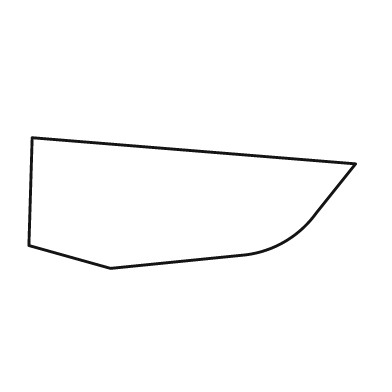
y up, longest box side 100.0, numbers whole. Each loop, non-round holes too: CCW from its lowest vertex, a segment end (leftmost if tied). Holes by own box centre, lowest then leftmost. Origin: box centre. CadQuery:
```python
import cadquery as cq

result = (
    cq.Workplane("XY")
    .moveTo(-25.0, -20.0)
    .lineTo(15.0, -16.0)
    .threePointArc((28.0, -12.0), (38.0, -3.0))
    .lineTo(50.0, 12.0)
    .lineTo(-49.0, 20.0)
    .lineTo(-50.0, -13.0)
    .close()
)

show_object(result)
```